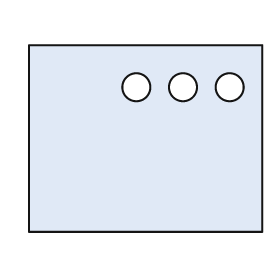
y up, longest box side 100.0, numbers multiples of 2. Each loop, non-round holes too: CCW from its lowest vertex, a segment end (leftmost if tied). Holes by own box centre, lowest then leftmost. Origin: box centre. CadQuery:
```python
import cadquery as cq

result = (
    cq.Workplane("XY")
    .moveTo(-50.0, -40.0)
    .lineTo(50.0, -40.0)
    .lineTo(50.0, 40.0)
    .lineTo(-50.0, 40.0)
    .close()
    .moveTo(-4.0, 22.0)
    .circle(6.0)
    .moveTo(16.0, 22.0)
    .circle(6.0)
    .moveTo(36.0, 22.0)
    .circle(6.0)
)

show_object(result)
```